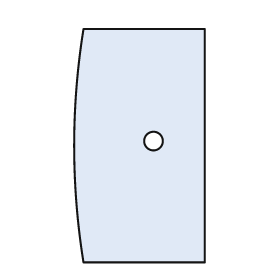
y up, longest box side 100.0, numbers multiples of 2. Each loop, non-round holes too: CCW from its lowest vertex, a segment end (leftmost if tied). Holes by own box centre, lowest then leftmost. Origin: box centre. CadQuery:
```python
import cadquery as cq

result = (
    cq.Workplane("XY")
    .moveTo(-24.0, -50.0)
    .lineTo(28.0, -50.0)
    .lineTo(28.0, 50.0)
    .lineTo(-24.0, 50.0)
    .threePointArc((-28.0, 0.0), (-24.0, -50.0))
    .close()
    .moveTo(6.0, 2.0)
    .circle(4.0)
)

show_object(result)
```